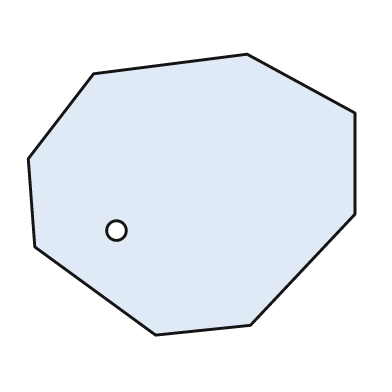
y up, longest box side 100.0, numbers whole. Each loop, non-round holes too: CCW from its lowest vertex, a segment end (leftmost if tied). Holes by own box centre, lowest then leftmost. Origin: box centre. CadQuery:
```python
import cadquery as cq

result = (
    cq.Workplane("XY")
    .moveTo(-11.0, -43.0)
    .lineTo(18.0, -40.0)
    .lineTo(50.0, -6.0)
    .lineTo(50.0, 25.0)
    .lineTo(17.0, 43.0)
    .lineTo(-30.0, 37.0)
    .lineTo(-50.0, 11.0)
    .lineTo(-48.0, -16.0)
    .close()
    .moveTo(-23.0, -11.0)
    .circle(3.0)
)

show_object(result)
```